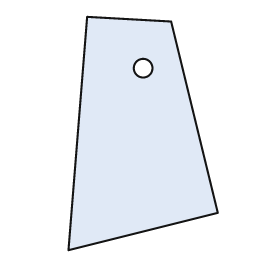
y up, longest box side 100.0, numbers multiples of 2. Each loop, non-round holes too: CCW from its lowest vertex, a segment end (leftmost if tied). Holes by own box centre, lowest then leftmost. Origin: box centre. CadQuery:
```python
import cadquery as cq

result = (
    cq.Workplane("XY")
    .moveTo(-32.0, -50.0)
    .lineTo(32.0, -34.0)
    .lineTo(12.0, 48.0)
    .lineTo(-24.0, 50.0)
    .close()
    .moveTo(0.0, 28.0)
    .circle(4.0)
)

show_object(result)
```